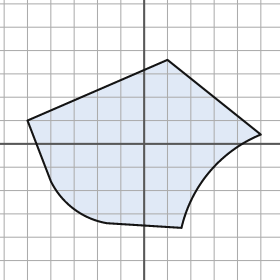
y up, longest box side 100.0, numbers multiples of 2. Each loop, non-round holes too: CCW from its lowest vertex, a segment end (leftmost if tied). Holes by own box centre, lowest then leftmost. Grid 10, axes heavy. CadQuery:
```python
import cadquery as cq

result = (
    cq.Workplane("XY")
    .moveTo(16.0, -36.0)
    .threePointArc((28.0, -12.0), (50.0, 4.0))
    .lineTo(10.0, 36.0)
    .lineTo(-50.0, 10.0)
    .lineTo(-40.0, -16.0)
    .threePointArc((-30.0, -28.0), (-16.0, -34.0))
    .close()
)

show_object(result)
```